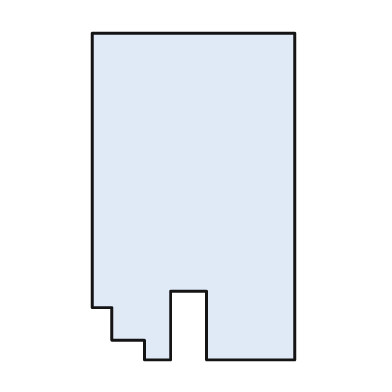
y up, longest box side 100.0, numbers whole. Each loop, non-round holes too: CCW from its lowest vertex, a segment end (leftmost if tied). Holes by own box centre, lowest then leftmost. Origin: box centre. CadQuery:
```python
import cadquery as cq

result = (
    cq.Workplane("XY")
    .moveTo(-15.0, -50.0)
    .lineTo(-7.0, -50.0)
    .lineTo(-7.0, -29.0)
    .lineTo(4.0, -29.0)
    .lineTo(4.0, -50.0)
    .lineTo(31.0, -50.0)
    .lineTo(31.0, 50.0)
    .lineTo(-31.0, 50.0)
    .lineTo(-31.0, -34.0)
    .lineTo(-25.0, -34.0)
    .lineTo(-25.0, -44.0)
    .lineTo(-15.0, -44.0)
    .close()
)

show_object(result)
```